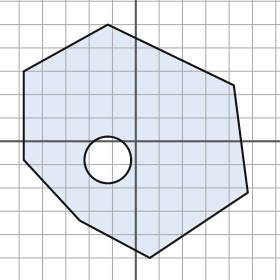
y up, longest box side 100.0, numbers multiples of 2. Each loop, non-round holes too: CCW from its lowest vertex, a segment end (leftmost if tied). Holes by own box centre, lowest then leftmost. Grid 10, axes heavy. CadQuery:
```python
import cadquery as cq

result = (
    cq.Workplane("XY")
    .moveTo(6.0, -50.0)
    .lineTo(48.0, -22.0)
    .lineTo(42.0, 24.0)
    .lineTo(-12.0, 50.0)
    .lineTo(-48.0, 30.0)
    .lineTo(-48.0, -8.0)
    .lineTo(-24.0, -34.0)
    .close()
    .moveTo(-12.0, -8.0)
    .circle(10.0)
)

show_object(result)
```